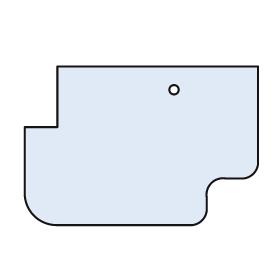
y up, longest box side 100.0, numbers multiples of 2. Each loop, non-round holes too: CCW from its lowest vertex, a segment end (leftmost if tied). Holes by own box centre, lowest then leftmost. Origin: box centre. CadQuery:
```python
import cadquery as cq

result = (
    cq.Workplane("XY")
    .moveTo(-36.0, -34.0)
    .lineTo(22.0, -34.0)
    .threePointArc((26.0, -32.0), (28.0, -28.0))
    .lineTo(28.0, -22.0)
    .threePointArc((30.0, -16.0), (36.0, -14.0))
    .lineTo(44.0, -14.0)
    .threePointArc((48.0, -12.0), (50.0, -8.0))
    .lineTo(50.0, 34.0)
    .lineTo(-36.0, 34.0)
    .lineTo(-36.0, 8.0)
    .lineTo(-50.0, 8.0)
    .lineTo(-50.0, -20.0)
    .threePointArc((-46.0, -30.0), (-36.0, -34.0))
    .close()
    .moveTo(14.0, 24.0)
    .circle(2.0)
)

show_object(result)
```